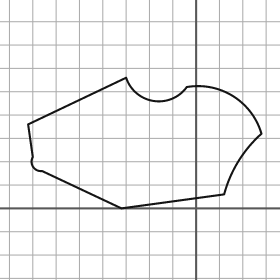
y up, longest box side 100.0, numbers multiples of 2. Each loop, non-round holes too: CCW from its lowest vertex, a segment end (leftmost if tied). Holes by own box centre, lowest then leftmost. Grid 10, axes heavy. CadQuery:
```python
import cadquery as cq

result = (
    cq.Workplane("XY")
    .moveTo(-32.0, 0.0)
    .lineTo(12.0, 6.0)
    .threePointArc((18.0, 20.0), (28.0, 32.0))
    .threePointArc((16.0, 48.0), (-4.0, 52.0))
    .threePointArc((-18.0, 46.0), (-30.0, 56.0))
    .lineTo(-72.0, 36.0)
    .lineTo(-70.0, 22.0)
    .threePointArc((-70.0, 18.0), (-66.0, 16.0))
    .close()
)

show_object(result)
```